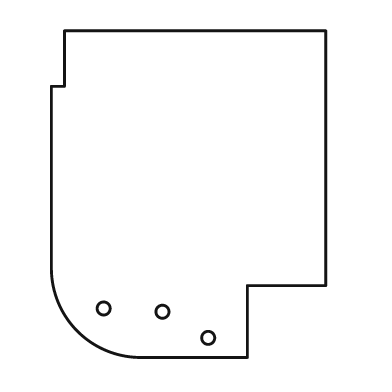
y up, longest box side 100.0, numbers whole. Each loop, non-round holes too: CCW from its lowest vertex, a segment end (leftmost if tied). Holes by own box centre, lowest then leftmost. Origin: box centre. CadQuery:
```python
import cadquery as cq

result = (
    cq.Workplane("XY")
    .moveTo(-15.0, -50.0)
    .lineTo(18.0, -50.0)
    .lineTo(18.0, -28.0)
    .lineTo(42.0, -28.0)
    .lineTo(42.0, 50.0)
    .lineTo(-38.0, 50.0)
    .lineTo(-38.0, 33.0)
    .lineTo(-42.0, 33.0)
    .lineTo(-42.0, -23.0)
    .threePointArc((-34.0, -42.0), (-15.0, -50.0))
    .close()
    .moveTo(6.0, -44.0)
    .circle(2.0)
    .moveTo(-8.0, -36.0)
    .circle(2.0)
    .moveTo(-26.0, -35.0)
    .circle(2.0)
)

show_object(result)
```